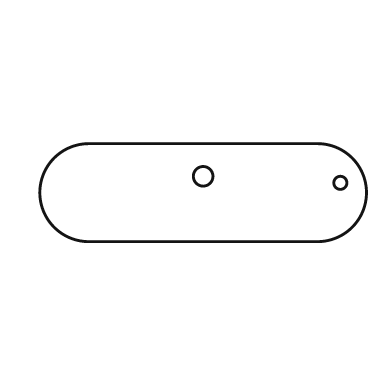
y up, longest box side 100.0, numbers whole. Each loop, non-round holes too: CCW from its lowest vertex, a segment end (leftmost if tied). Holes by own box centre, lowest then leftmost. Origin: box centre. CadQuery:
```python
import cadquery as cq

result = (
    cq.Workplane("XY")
    .moveTo(-35.0, -15.0)
    .lineTo(35.0, -15.0)
    .threePointArc((50.0, 0.0), (35.0, 15.0))
    .lineTo(-35.0, 15.0)
    .threePointArc((-50.0, 0.0), (-35.0, -15.0))
    .close()
    .moveTo(42.0, 3.0)
    .circle(2.0)
    .moveTo(0.0, 5.0)
    .circle(3.0)
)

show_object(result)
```